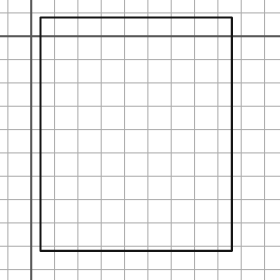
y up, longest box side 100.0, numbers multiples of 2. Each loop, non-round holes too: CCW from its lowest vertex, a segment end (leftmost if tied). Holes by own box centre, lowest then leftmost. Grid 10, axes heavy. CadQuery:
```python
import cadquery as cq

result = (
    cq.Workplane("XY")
    .moveTo(4.0, -92.0)
    .lineTo(86.0, -92.0)
    .lineTo(86.0, 8.0)
    .lineTo(4.0, 8.0)
    .close()
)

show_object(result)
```